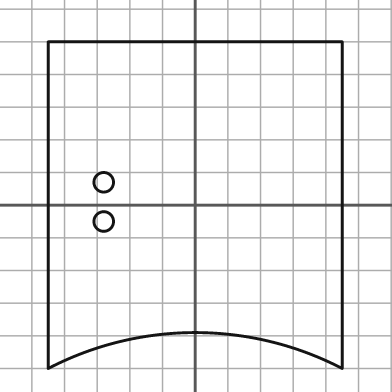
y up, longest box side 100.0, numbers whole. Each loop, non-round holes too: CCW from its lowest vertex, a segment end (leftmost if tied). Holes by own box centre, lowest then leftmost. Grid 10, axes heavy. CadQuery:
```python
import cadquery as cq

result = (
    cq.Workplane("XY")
    .moveTo(-45.0, -50.0)
    .threePointArc((0.0, -39.0), (45.0, -50.0))
    .lineTo(45.0, 50.0)
    .lineTo(-45.0, 50.0)
    .close()
    .moveTo(-28.0, -5.0)
    .circle(3.0)
    .moveTo(-28.0, 7.0)
    .circle(3.0)
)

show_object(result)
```